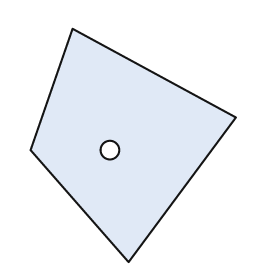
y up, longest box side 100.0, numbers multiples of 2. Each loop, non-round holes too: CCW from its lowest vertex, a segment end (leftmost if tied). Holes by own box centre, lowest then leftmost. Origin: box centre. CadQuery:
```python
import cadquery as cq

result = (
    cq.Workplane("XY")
    .moveTo(-2.0, -50.0)
    .lineTo(44.0, 12.0)
    .lineTo(-26.0, 50.0)
    .lineTo(-44.0, -2.0)
    .close()
    .moveTo(-10.0, -2.0)
    .circle(4.0)
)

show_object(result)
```